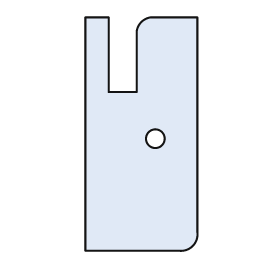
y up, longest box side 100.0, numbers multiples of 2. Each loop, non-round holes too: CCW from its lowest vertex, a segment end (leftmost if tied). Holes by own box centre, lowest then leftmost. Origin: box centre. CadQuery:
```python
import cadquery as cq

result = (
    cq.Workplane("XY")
    .moveTo(-24.0, -50.0)
    .lineTo(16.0, -50.0)
    .threePointArc((22.0, -48.0), (24.0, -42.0))
    .lineTo(24.0, 50.0)
    .lineTo(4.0, 50.0)
    .threePointArc((0.0, 48.0), (-2.0, 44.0))
    .lineTo(-2.0, 18.0)
    .lineTo(-14.0, 18.0)
    .lineTo(-14.0, 50.0)
    .lineTo(-24.0, 50.0)
    .close()
    .moveTo(6.0, -2.0)
    .circle(4.0)
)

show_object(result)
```